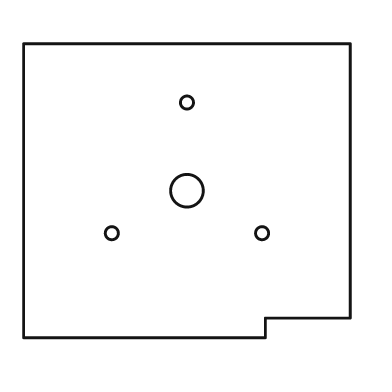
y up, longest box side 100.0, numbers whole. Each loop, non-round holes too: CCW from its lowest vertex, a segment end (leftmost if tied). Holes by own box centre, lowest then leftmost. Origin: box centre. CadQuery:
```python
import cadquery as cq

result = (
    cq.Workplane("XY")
    .moveTo(-50.0, -45.0)
    .lineTo(24.0, -45.0)
    .lineTo(24.0, -39.0)
    .lineTo(50.0, -39.0)
    .lineTo(50.0, 45.0)
    .lineTo(-50.0, 45.0)
    .close()
    .moveTo(-23.0, -13.0)
    .circle(2.0)
    .moveTo(23.0, -13.0)
    .circle(2.0)
    .moveTo(0.0, 0.0)
    .circle(5.0)
    .moveTo(0.0, 27.0)
    .circle(2.0)
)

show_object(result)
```